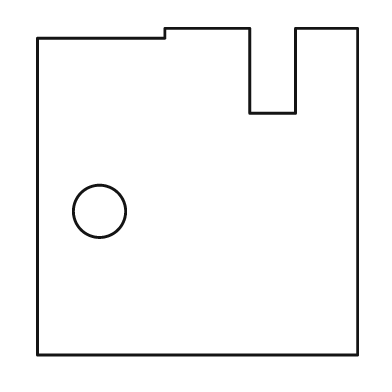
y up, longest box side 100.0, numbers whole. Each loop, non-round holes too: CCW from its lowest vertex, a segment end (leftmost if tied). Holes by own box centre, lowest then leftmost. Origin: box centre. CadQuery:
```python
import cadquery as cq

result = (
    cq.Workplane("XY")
    .moveTo(-49.0, -50.0)
    .lineTo(49.0, -50.0)
    .lineTo(49.0, 50.0)
    .lineTo(30.0, 50.0)
    .lineTo(30.0, 24.0)
    .lineTo(16.0, 24.0)
    .lineTo(16.0, 50.0)
    .lineTo(-10.0, 50.0)
    .lineTo(-10.0, 47.0)
    .lineTo(-49.0, 47.0)
    .close()
    .moveTo(-30.0, -6.0)
    .circle(8.0)
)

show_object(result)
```